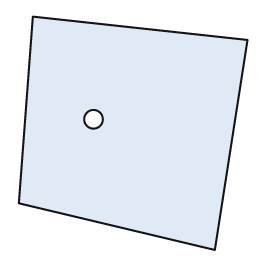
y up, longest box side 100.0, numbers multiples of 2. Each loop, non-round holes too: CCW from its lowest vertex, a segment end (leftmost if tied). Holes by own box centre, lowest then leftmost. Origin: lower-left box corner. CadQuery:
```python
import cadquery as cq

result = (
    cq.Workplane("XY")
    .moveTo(84.0, 0.0)
    .lineTo(98.0, 90.0)
    .lineTo(6.0, 100.0)
    .lineTo(0.0, 20.0)
    .close()
    .moveTo(32.0, 56.0)
    .circle(4.0)
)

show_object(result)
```